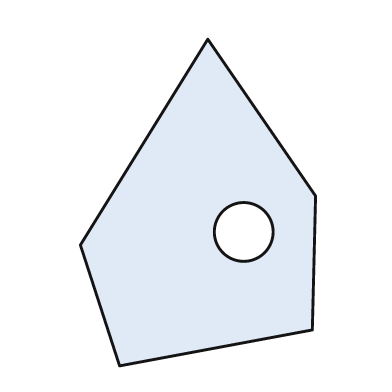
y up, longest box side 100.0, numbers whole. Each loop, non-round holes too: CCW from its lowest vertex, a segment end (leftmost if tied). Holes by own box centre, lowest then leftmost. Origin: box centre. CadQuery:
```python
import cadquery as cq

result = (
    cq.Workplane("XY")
    .moveTo(-24.0, -50.0)
    .lineTo(35.0, -39.0)
    .lineTo(36.0, 2.0)
    .lineTo(3.0, 50.0)
    .lineTo(-36.0, -13.0)
    .close()
    .moveTo(14.0, -9.0)
    .circle(9.0)
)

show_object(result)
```